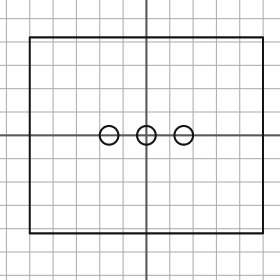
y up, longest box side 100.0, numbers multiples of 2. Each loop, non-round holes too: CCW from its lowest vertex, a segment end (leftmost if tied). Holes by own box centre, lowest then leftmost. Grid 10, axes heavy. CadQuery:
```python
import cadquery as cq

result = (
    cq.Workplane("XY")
    .moveTo(-50.0, -42.0)
    .lineTo(50.0, -42.0)
    .lineTo(50.0, 42.0)
    .lineTo(-50.0, 42.0)
    .close()
    .moveTo(-16.0, 0.0)
    .circle(4.0)
    .moveTo(0.0, 0.0)
    .circle(4.0)
    .moveTo(16.0, 0.0)
    .circle(4.0)
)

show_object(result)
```